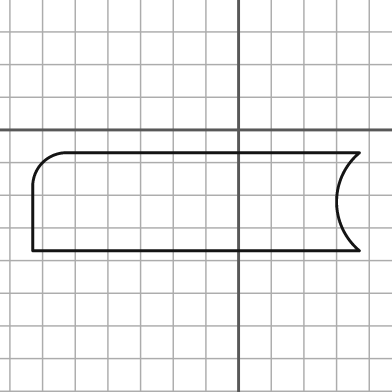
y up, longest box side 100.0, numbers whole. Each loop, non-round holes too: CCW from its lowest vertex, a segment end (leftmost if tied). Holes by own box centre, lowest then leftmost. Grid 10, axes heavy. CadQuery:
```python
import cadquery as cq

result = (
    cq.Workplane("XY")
    .moveTo(-63.0, -37.0)
    .lineTo(37.0, -37.0)
    .threePointArc((30.0, -22.0), (37.0, -7.0))
    .lineTo(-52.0, -7.0)
    .threePointArc((-60.0, -10.0), (-63.0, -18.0))
    .close()
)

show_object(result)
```